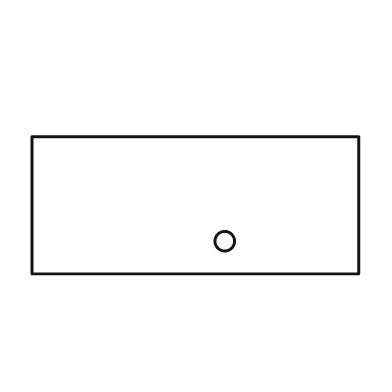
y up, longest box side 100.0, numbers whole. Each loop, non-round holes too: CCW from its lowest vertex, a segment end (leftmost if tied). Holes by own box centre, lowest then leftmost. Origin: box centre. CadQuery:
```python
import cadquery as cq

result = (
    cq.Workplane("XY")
    .moveTo(-50.0, -21.0)
    .lineTo(50.0, -21.0)
    .lineTo(50.0, 21.0)
    .lineTo(-50.0, 21.0)
    .close()
    .moveTo(9.0, -11.0)
    .circle(3.0)
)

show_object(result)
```